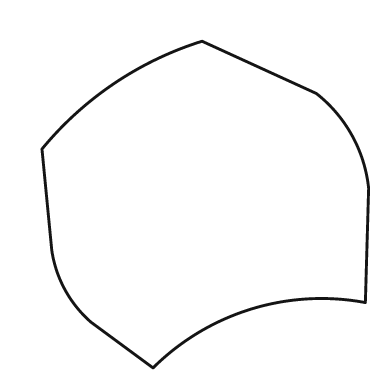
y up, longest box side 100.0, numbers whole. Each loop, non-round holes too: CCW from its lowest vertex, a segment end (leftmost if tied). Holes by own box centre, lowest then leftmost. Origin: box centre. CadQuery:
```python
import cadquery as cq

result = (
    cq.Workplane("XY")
    .moveTo(-16.0, -50.0)
    .threePointArc((14.0, -32.0), (49.0, -30.0))
    .lineTo(50.0, 5.0)
    .threePointArc((45.0, 21.0), (34.0, 34.0))
    .lineTo(-1.0, 50.0)
    .threePointArc((-28.0, 37.0), (-50.0, 17.0))
    .lineTo(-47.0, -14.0)
    .threePointArc((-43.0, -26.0), (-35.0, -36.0))
    .close()
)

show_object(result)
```